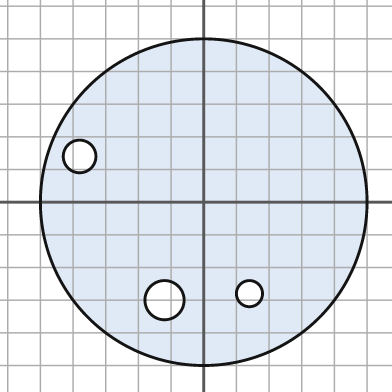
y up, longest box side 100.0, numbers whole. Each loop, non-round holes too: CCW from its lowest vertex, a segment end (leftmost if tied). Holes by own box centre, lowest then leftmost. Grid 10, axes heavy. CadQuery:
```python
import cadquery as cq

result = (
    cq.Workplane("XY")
    .moveTo(0.0, 0.0)
    .circle(50.0)
    .moveTo(-12.0, -30.0)
    .circle(6.0)
    .moveTo(14.0, -28.0)
    .circle(4.0)
    .moveTo(-38.0, 14.0)
    .circle(5.0)
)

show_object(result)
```